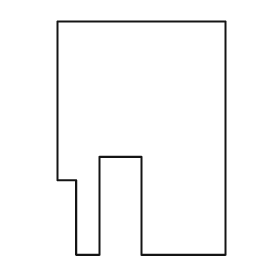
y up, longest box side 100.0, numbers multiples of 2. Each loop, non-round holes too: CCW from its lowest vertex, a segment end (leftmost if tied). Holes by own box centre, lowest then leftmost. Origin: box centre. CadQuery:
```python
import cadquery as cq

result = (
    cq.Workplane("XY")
    .moveTo(-28.0, -50.0)
    .lineTo(-18.0, -50.0)
    .lineTo(-18.0, -8.0)
    .lineTo(0.0, -8.0)
    .lineTo(0.0, -50.0)
    .lineTo(36.0, -50.0)
    .lineTo(36.0, 50.0)
    .lineTo(-36.0, 50.0)
    .lineTo(-36.0, -18.0)
    .lineTo(-28.0, -18.0)
    .close()
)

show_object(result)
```